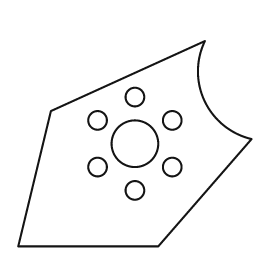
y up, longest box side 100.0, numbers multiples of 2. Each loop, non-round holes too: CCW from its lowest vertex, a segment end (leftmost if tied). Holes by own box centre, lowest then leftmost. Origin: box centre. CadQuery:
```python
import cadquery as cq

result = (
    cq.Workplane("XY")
    .moveTo(-50.0, -44.0)
    .lineTo(10.0, -44.0)
    .lineTo(50.0, 2.0)
    .threePointArc((30.0, 18.0), (30.0, 44.0))
    .lineTo(-36.0, 14.0)
    .close()
    .moveTo(0.0, -20.0)
    .circle(4.0)
    .moveTo(-16.0, -10.0)
    .circle(4.0)
    .moveTo(16.0, -10.0)
    .circle(4.0)
    .moveTo(0.0, 0.0)
    .circle(10.0)
    .moveTo(-16.0, 10.0)
    .circle(4.0)
    .moveTo(16.0, 10.0)
    .circle(4.0)
    .moveTo(0.0, 20.0)
    .circle(4.0)
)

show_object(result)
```